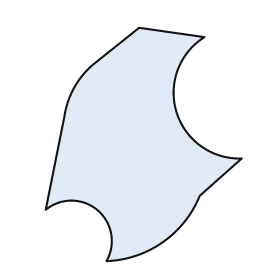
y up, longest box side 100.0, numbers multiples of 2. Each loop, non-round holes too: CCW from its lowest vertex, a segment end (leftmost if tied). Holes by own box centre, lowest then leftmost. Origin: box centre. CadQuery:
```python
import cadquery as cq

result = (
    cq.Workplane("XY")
    .moveTo(-16.0, -50.0)
    .threePointArc((8.0, -42.0), (24.0, -22.0))
    .lineTo(42.0, -6.0)
    .threePointArc((14.0, 14.0), (26.0, 46.0))
    .lineTo(-2.0, 50.0)
    .lineTo(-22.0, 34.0)
    .threePointArc((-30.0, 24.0), (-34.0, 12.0))
    .lineTo(-42.0, -28.0)
    .threePointArc((-20.0, -28.0), (-16.0, -50.0))
    .close()
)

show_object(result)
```